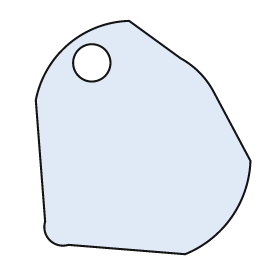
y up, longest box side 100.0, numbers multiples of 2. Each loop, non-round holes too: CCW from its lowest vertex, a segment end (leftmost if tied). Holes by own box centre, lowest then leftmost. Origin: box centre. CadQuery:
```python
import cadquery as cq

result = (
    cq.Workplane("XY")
    .moveTo(18.0, -50.0)
    .threePointArc((38.0, -34.0), (46.0, -10.0))
    .lineTo(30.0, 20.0)
    .threePointArc((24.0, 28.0), (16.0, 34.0))
    .lineTo(-6.0, 50.0)
    .threePointArc((-32.0, 40.0), (-46.0, 16.0))
    .lineTo(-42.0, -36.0)
    .threePointArc((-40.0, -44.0), (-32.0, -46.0))
    .close()
    .moveTo(-22.0, 32.0)
    .circle(8.0)
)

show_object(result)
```